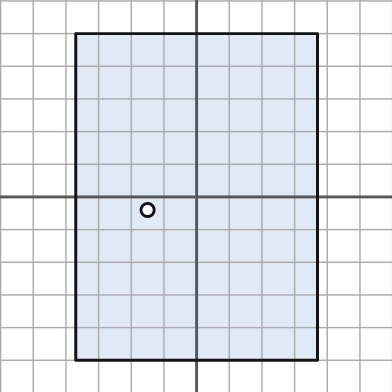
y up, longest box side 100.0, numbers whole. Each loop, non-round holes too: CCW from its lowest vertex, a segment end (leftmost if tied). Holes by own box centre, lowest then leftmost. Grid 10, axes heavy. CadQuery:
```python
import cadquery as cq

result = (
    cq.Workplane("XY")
    .moveTo(-37.0, -50.0)
    .lineTo(37.0, -50.0)
    .lineTo(37.0, 50.0)
    .lineTo(-37.0, 50.0)
    .close()
    .moveTo(-15.0, -4.0)
    .circle(2.0)
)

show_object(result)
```